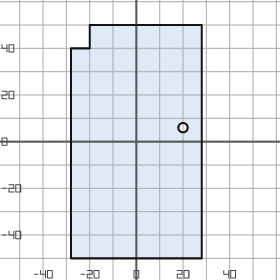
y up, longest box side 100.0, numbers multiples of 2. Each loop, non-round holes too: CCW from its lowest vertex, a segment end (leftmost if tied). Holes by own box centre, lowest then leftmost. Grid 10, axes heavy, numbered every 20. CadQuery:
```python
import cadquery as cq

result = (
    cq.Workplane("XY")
    .moveTo(-28.0, -50.0)
    .lineTo(28.0, -50.0)
    .lineTo(28.0, 50.0)
    .lineTo(-20.0, 50.0)
    .lineTo(-20.0, 40.0)
    .lineTo(-28.0, 40.0)
    .close()
    .moveTo(20.0, 6.0)
    .circle(2.0)
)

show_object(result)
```